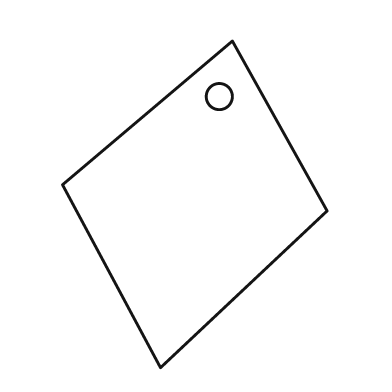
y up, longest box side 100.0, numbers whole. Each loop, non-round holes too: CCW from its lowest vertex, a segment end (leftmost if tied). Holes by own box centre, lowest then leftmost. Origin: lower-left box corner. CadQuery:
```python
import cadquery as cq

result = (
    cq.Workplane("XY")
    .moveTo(30.0, 0.0)
    .lineTo(81.0, 48.0)
    .lineTo(52.0, 100.0)
    .lineTo(0.0, 56.0)
    .close()
    .moveTo(48.0, 83.0)
    .circle(4.0)
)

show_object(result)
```